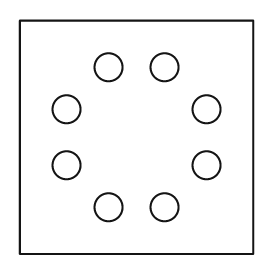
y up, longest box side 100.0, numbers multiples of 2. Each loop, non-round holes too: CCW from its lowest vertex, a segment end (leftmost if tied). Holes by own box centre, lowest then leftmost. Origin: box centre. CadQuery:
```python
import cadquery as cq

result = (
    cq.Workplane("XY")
    .moveTo(-50.0, -50.0)
    .lineTo(50.0, -50.0)
    .lineTo(50.0, 50.0)
    .lineTo(-50.0, 50.0)
    .close()
    .moveTo(-12.0, -30.0)
    .circle(6.0)
    .moveTo(12.0, -30.0)
    .circle(6.0)
    .moveTo(-30.0, -12.0)
    .circle(6.0)
    .moveTo(30.0, -12.0)
    .circle(6.0)
    .moveTo(-30.0, 12.0)
    .circle(6.0)
    .moveTo(30.0, 12.0)
    .circle(6.0)
    .moveTo(-12.0, 30.0)
    .circle(6.0)
    .moveTo(12.0, 30.0)
    .circle(6.0)
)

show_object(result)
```